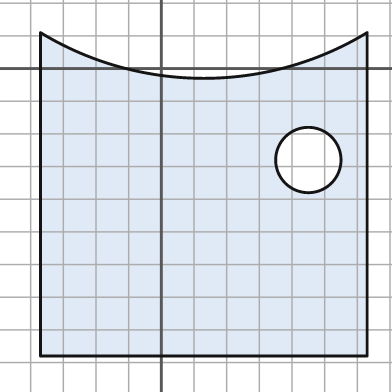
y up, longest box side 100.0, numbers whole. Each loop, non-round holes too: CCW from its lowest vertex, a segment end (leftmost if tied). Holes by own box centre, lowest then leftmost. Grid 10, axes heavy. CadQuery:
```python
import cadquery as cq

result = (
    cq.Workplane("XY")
    .moveTo(-37.0, -88.0)
    .lineTo(63.0, -88.0)
    .lineTo(63.0, 11.0)
    .threePointArc((13.0, -3.0), (-37.0, 11.0))
    .close()
    .moveTo(45.0, -28.0)
    .circle(10.0)
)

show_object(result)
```